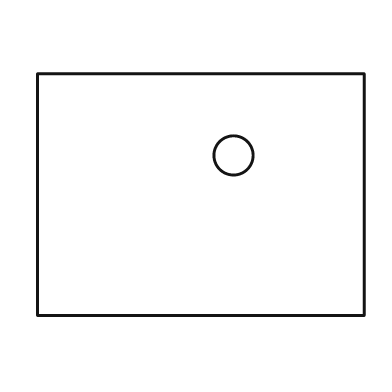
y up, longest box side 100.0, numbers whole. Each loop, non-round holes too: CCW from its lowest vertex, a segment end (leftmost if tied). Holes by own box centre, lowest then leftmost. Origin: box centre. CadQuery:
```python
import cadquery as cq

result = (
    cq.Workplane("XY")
    .moveTo(-50.0, -37.0)
    .lineTo(50.0, -37.0)
    .lineTo(50.0, 37.0)
    .lineTo(-50.0, 37.0)
    .close()
    .moveTo(10.0, 12.0)
    .circle(6.0)
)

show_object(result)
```